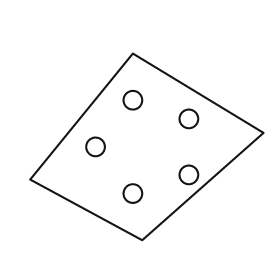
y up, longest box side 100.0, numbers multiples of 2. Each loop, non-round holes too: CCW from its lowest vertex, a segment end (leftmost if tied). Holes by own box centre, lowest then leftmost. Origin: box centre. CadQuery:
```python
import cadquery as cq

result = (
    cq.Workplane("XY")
    .moveTo(-2.0, -40.0)
    .lineTo(50.0, 6.0)
    .lineTo(-6.0, 40.0)
    .lineTo(-50.0, -14.0)
    .close()
    .moveTo(-6.0, -20.0)
    .circle(4.0)
    .moveTo(18.0, -12.0)
    .circle(4.0)
    .moveTo(-22.0, 0.0)
    .circle(4.0)
    .moveTo(18.0, 12.0)
    .circle(4.0)
    .moveTo(-6.0, 20.0)
    .circle(4.0)
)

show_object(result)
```